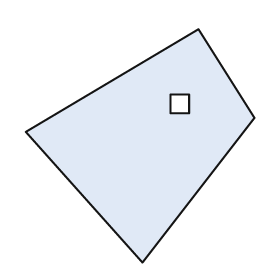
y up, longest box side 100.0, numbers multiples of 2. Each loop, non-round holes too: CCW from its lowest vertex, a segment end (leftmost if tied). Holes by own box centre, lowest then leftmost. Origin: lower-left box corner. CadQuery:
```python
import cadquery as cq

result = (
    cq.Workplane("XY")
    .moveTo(50.0, 0.0)
    .lineTo(98.0, 62.0)
    .lineTo(74.0, 100.0)
    .lineTo(0.0, 56.0)
    .close()
    .moveTo(62.0, 64.0)
    .lineTo(70.0, 64.0)
    .lineTo(70.0, 72.0)
    .lineTo(62.0, 72.0)
    .close()
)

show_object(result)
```